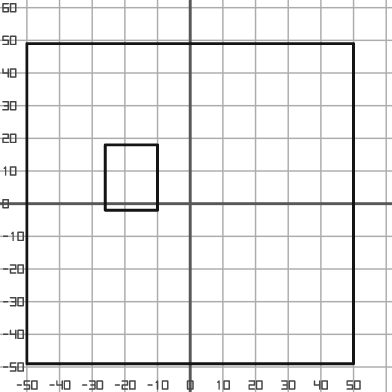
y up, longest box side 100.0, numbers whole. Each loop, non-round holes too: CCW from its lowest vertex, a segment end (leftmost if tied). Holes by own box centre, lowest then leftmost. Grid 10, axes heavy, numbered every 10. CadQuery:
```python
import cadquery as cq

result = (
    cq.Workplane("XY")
    .moveTo(-50.0, -49.0)
    .lineTo(50.0, -49.0)
    .lineTo(50.0, 49.0)
    .lineTo(-50.0, 49.0)
    .close()
    .moveTo(-26.0, -2.0)
    .lineTo(-10.0, -2.0)
    .lineTo(-10.0, 18.0)
    .lineTo(-26.0, 18.0)
    .close()
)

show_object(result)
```